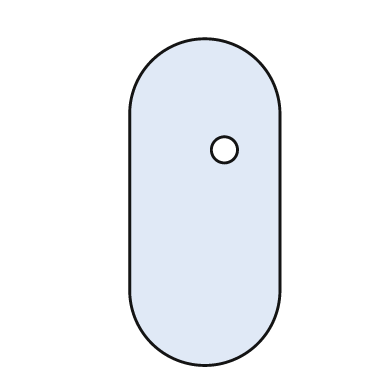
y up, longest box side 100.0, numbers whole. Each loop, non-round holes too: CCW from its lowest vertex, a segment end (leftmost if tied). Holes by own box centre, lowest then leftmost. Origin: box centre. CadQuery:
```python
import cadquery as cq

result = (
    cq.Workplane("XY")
    .moveTo(-23.0, -27.0)
    .threePointArc((0.0, -50.0), (23.0, -27.0))
    .lineTo(23.0, 27.0)
    .threePointArc((0.0, 50.0), (-23.0, 27.0))
    .close()
    .moveTo(6.0, 16.0)
    .circle(4.0)
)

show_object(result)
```